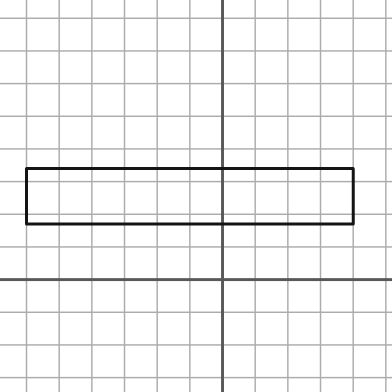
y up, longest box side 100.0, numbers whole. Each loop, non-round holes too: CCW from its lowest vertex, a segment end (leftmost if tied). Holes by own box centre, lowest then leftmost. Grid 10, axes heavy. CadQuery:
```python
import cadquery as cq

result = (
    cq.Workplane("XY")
    .moveTo(-60.0, 17.0)
    .lineTo(40.0, 17.0)
    .lineTo(40.0, 34.0)
    .lineTo(-60.0, 34.0)
    .close()
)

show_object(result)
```